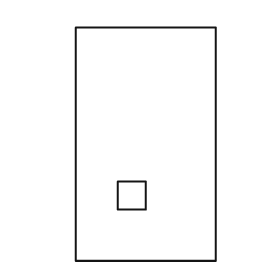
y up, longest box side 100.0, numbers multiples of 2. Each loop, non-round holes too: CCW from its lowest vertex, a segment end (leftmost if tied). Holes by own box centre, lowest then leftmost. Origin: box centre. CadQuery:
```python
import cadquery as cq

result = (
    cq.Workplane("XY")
    .moveTo(-30.0, -50.0)
    .lineTo(30.0, -50.0)
    .lineTo(30.0, 50.0)
    .lineTo(-30.0, 50.0)
    .close()
    .moveTo(-12.0, -28.0)
    .lineTo(0.0, -28.0)
    .lineTo(0.0, -16.0)
    .lineTo(-12.0, -16.0)
    .close()
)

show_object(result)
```